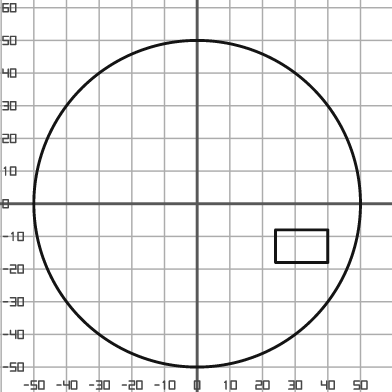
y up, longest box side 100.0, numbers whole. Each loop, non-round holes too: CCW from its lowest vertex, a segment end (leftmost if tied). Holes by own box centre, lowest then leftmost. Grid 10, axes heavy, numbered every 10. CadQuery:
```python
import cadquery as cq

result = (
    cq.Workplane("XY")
    .moveTo(0.0, 0.0)
    .circle(50.0)
    .moveTo(24.0, -18.0)
    .lineTo(40.0, -18.0)
    .lineTo(40.0, -8.0)
    .lineTo(24.0, -8.0)
    .close()
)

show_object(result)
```